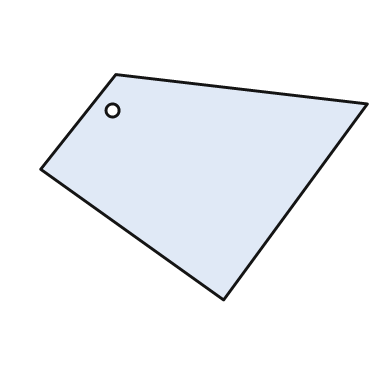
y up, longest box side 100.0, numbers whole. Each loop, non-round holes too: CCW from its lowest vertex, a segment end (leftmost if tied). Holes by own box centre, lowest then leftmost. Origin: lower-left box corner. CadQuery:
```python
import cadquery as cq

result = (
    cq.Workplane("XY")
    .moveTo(56.0, 0.0)
    .lineTo(100.0, 60.0)
    .lineTo(23.0, 69.0)
    .lineTo(0.0, 40.0)
    .close()
    .moveTo(22.0, 58.0)
    .circle(2.0)
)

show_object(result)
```